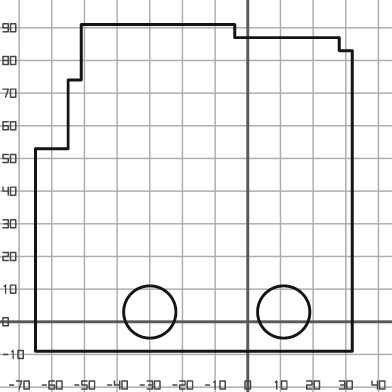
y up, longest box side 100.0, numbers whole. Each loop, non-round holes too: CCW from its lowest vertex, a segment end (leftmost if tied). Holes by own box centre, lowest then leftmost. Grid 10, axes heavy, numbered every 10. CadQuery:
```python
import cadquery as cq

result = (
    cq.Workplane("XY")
    .moveTo(-65.0, -9.0)
    .lineTo(32.0, -9.0)
    .lineTo(32.0, 83.0)
    .lineTo(28.0, 83.0)
    .lineTo(28.0, 87.0)
    .lineTo(-4.0, 87.0)
    .lineTo(-4.0, 91.0)
    .lineTo(-51.0, 91.0)
    .lineTo(-51.0, 74.0)
    .lineTo(-55.0, 74.0)
    .lineTo(-55.0, 53.0)
    .lineTo(-65.0, 53.0)
    .close()
    .moveTo(-30.0, 3.0)
    .circle(8.0)
    .moveTo(11.0, 3.0)
    .circle(8.0)
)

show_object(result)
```